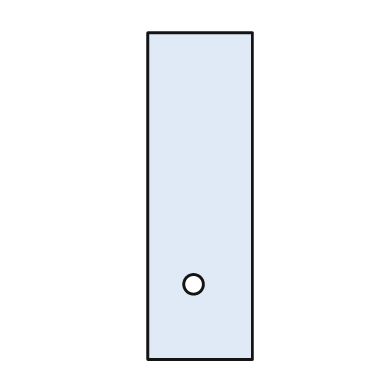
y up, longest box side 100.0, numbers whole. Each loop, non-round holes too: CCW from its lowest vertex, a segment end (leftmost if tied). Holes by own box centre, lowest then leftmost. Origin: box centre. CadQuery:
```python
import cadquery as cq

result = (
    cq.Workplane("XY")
    .moveTo(-16.0, -50.0)
    .lineTo(16.0, -50.0)
    .lineTo(16.0, 50.0)
    .lineTo(-16.0, 50.0)
    .close()
    .moveTo(-2.0, -27.0)
    .circle(3.0)
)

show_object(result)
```